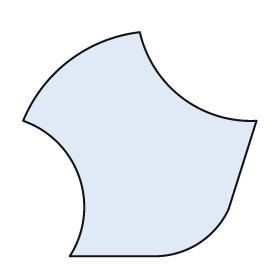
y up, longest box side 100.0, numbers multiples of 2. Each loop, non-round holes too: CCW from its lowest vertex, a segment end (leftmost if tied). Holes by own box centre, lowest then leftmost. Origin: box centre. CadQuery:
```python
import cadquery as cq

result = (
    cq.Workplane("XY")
    .moveTo(-30.0, -48.0)
    .lineTo(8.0, -48.0)
    .threePointArc((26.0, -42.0), (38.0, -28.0))
    .lineTo(50.0, 10.0)
    .threePointArc((18.0, 20.0), (0.0, 48.0))
    .threePointArc((-30.0, 36.0), (-50.0, 10.0))
    .threePointArc((-26.0, -14.0), (-30.0, -48.0))
    .close()
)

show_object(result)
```